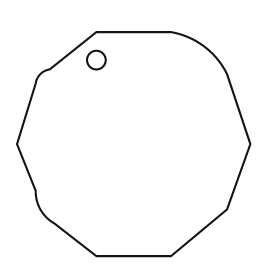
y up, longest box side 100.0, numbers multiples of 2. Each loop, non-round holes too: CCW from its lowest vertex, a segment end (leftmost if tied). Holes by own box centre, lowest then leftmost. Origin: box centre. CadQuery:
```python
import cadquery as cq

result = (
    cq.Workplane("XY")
    .moveTo(-16.0, -48.0)
    .lineTo(16.0, -48.0)
    .lineTo(40.0, -28.0)
    .lineTo(50.0, 0.0)
    .lineTo(40.0, 30.0)
    .threePointArc((30.0, 42.0), (16.0, 48.0))
    .lineTo(-16.0, 48.0)
    .lineTo(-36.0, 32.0)
    .threePointArc((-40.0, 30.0), (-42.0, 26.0))
    .lineTo(-50.0, 0.0)
    .lineTo(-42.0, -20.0)
    .threePointArc((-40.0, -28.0), (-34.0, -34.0))
    .close()
    .moveTo(-16.0, 36.0)
    .circle(4.0)
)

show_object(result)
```